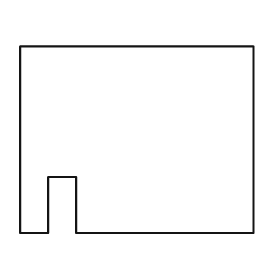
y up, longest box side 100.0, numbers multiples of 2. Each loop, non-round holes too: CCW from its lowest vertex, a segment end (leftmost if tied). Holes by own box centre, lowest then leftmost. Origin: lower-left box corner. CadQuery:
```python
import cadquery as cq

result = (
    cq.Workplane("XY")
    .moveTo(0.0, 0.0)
    .lineTo(12.0, 0.0)
    .lineTo(12.0, 24.0)
    .lineTo(24.0, 24.0)
    .lineTo(24.0, 0.0)
    .lineTo(100.0, 0.0)
    .lineTo(100.0, 80.0)
    .lineTo(0.0, 80.0)
    .close()
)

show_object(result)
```